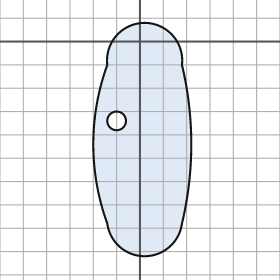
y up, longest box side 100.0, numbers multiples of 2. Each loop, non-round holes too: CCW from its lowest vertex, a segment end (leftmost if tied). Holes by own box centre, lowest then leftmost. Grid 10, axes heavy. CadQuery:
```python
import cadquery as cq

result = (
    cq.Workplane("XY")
    .moveTo(-14.0, -78.0)
    .threePointArc((2.0, -92.0), (18.0, -78.0))
    .threePointArc((22.0, -44.0), (18.0, -10.0))
    .threePointArc((2.0, 8.0), (-14.0, -10.0))
    .threePointArc((-20.0, -44.0), (-14.0, -78.0))
    .close()
    .moveTo(-10.0, -34.0)
    .circle(4.0)
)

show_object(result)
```